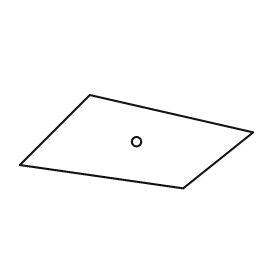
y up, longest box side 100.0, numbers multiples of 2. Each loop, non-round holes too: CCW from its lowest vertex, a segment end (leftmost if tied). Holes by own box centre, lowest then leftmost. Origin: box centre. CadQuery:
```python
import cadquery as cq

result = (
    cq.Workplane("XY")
    .moveTo(20.0, -20.0)
    .lineTo(50.0, 4.0)
    .lineTo(-20.0, 20.0)
    .lineTo(-50.0, -10.0)
    .close()
    .moveTo(0.0, 0.0)
    .circle(2.0)
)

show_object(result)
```